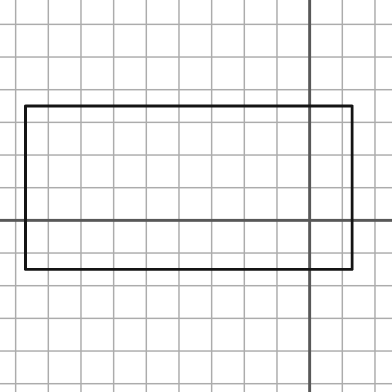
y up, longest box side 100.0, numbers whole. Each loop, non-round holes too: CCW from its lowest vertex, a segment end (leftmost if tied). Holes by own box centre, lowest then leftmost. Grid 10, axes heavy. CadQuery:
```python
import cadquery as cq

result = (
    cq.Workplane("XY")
    .moveTo(-87.0, -15.0)
    .lineTo(13.0, -15.0)
    .lineTo(13.0, 35.0)
    .lineTo(-87.0, 35.0)
    .close()
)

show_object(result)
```